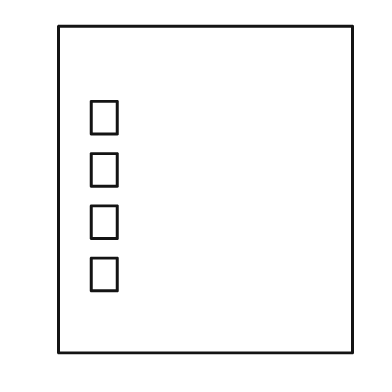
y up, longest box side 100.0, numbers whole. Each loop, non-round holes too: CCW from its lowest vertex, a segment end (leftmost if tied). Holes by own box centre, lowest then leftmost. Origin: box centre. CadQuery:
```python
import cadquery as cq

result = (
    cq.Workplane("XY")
    .moveTo(-45.0, -50.0)
    .lineTo(45.0, -50.0)
    .lineTo(45.0, 50.0)
    .lineTo(-45.0, 50.0)
    .close()
    .moveTo(-35.0, -31.0)
    .lineTo(-27.0, -31.0)
    .lineTo(-27.0, -21.0)
    .lineTo(-35.0, -21.0)
    .close()
    .moveTo(-35.0, -15.0)
    .lineTo(-27.0, -15.0)
    .lineTo(-27.0, -5.0)
    .lineTo(-35.0, -5.0)
    .close()
    .moveTo(-35.0, 1.0)
    .lineTo(-27.0, 1.0)
    .lineTo(-27.0, 11.0)
    .lineTo(-35.0, 11.0)
    .close()
    .moveTo(-35.0, 17.0)
    .lineTo(-27.0, 17.0)
    .lineTo(-27.0, 27.0)
    .lineTo(-35.0, 27.0)
    .close()
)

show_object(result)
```